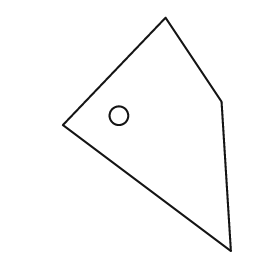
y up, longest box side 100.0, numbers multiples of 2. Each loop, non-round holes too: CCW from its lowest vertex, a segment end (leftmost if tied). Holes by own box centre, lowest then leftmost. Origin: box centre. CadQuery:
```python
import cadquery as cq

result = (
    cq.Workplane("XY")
    .moveTo(36.0, -50.0)
    .lineTo(32.0, 14.0)
    .lineTo(8.0, 50.0)
    .lineTo(-36.0, 4.0)
    .close()
    .moveTo(-12.0, 8.0)
    .circle(4.0)
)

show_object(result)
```